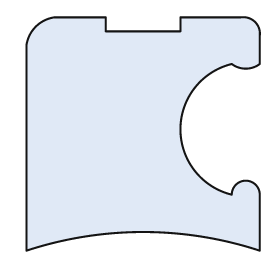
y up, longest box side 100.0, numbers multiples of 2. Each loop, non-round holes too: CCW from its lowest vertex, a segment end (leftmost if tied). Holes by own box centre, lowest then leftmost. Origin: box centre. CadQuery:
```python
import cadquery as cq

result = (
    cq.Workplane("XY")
    .moveTo(-50.0, -50.0)
    .threePointArc((0.0, -42.0), (50.0, -50.0))
    .lineTo(50.0, -26.0)
    .threePointArc((44.0, -20.0), (38.0, -26.0))
    .threePointArc((16.0, 2.0), (38.0, 30.0))
    .threePointArc((44.0, 28.0), (50.0, 30.0))
    .lineTo(50.0, 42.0)
    .threePointArc((48.0, 48.0), (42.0, 50.0))
    .lineTo(16.0, 50.0)
    .lineTo(16.0, 44.0)
    .lineTo(-16.0, 44.0)
    .lineTo(-16.0, 50.0)
    .lineTo(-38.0, 50.0)
    .threePointArc((-46.0, 46.0), (-50.0, 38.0))
    .close()
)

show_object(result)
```